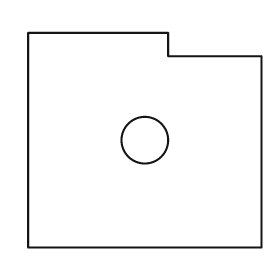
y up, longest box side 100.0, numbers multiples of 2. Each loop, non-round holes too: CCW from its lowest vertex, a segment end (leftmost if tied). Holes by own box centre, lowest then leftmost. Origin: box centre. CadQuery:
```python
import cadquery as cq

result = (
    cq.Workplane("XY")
    .moveTo(-50.0, -46.0)
    .lineTo(50.0, -46.0)
    .lineTo(50.0, 36.0)
    .lineTo(10.0, 36.0)
    .lineTo(10.0, 46.0)
    .lineTo(-50.0, 46.0)
    .close()
    .moveTo(0.0, 0.0)
    .circle(10.0)
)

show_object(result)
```